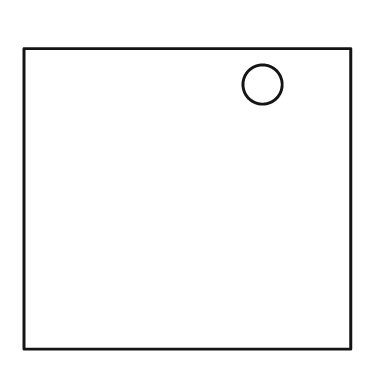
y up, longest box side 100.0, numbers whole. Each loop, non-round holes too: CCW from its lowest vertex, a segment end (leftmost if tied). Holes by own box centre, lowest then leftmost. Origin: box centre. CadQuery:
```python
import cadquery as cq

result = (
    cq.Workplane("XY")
    .moveTo(-50.0, -46.0)
    .lineTo(50.0, -46.0)
    .lineTo(50.0, 46.0)
    .lineTo(-50.0, 46.0)
    .close()
    .moveTo(23.0, 35.0)
    .circle(6.0)
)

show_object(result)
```